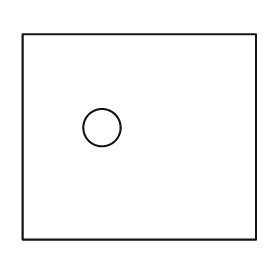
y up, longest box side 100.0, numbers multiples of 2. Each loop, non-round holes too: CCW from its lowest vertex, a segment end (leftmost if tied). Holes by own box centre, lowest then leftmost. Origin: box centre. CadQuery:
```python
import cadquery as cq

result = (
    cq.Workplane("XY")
    .moveTo(-50.0, -44.0)
    .lineTo(50.0, -44.0)
    .lineTo(50.0, 44.0)
    .lineTo(-50.0, 44.0)
    .close()
    .moveTo(-16.0, 4.0)
    .circle(8.0)
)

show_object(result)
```